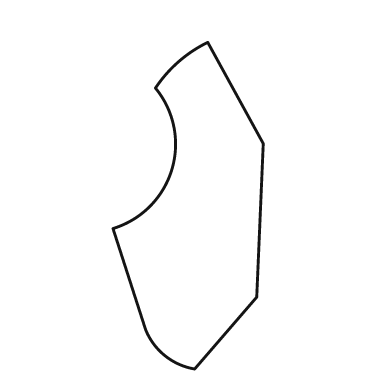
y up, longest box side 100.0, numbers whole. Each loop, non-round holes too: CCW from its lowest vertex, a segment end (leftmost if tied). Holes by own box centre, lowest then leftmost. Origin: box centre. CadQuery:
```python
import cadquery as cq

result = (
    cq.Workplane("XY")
    .moveTo(2.0, -50.0)
    .lineTo(21.0, -28.0)
    .lineTo(23.0, 19.0)
    .lineTo(6.0, 50.0)
    .threePointArc((-3.0, 44.0), (-10.0, 36.0))
    .threePointArc((-5.0, 11.0), (-23.0, -7.0))
    .lineTo(-13.0, -38.0)
    .threePointArc((-7.0, -46.0), (2.0, -50.0))
    .close()
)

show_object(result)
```